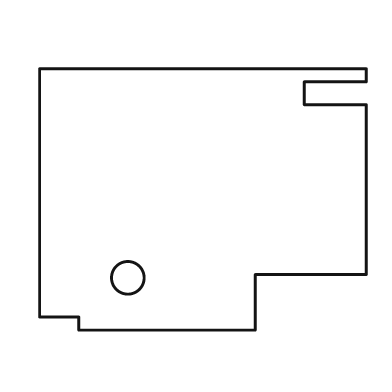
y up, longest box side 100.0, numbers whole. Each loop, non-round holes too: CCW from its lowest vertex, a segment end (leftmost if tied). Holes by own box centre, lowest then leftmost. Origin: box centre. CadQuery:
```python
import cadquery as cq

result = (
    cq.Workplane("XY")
    .moveTo(-38.0, -40.0)
    .lineTo(16.0, -40.0)
    .lineTo(16.0, -23.0)
    .lineTo(50.0, -23.0)
    .lineTo(50.0, 29.0)
    .lineTo(31.0, 29.0)
    .lineTo(31.0, 36.0)
    .lineTo(50.0, 36.0)
    .lineTo(50.0, 40.0)
    .lineTo(-50.0, 40.0)
    .lineTo(-50.0, -36.0)
    .lineTo(-38.0, -36.0)
    .close()
    .moveTo(-23.0, -24.0)
    .circle(5.0)
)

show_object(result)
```